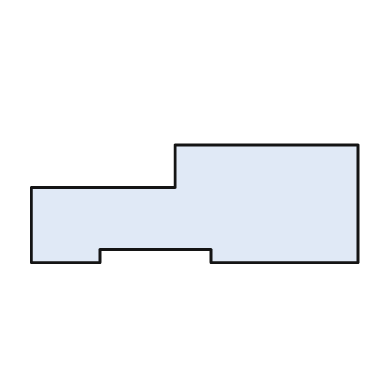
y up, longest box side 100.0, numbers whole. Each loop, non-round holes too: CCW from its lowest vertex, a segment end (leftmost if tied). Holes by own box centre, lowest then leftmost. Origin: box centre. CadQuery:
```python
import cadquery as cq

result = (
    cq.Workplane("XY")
    .moveTo(-50.0, -18.0)
    .lineTo(-29.0, -18.0)
    .lineTo(-29.0, -14.0)
    .lineTo(5.0, -14.0)
    .lineTo(5.0, -18.0)
    .lineTo(50.0, -18.0)
    .lineTo(50.0, 18.0)
    .lineTo(-6.0, 18.0)
    .lineTo(-6.0, 5.0)
    .lineTo(-50.0, 5.0)
    .close()
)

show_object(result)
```